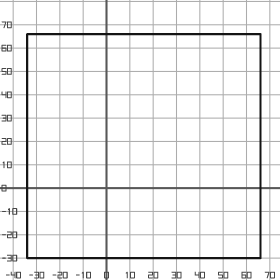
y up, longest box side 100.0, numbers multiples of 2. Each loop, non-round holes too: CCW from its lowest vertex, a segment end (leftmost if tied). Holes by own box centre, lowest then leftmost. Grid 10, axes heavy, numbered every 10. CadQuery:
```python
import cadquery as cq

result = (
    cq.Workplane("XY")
    .moveTo(-34.0, -30.0)
    .lineTo(66.0, -30.0)
    .lineTo(66.0, 66.0)
    .lineTo(-34.0, 66.0)
    .close()
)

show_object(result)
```